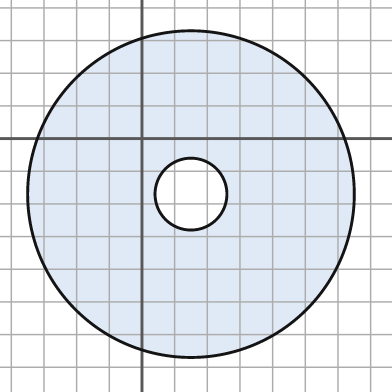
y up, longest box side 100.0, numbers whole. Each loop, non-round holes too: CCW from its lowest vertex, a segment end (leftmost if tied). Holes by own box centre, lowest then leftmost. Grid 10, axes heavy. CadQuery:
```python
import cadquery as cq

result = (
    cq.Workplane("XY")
    .moveTo(15.0, -17.0)
    .circle(50.0)
    .moveTo(15.0, -17.0)
    .circle(11.0)
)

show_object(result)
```